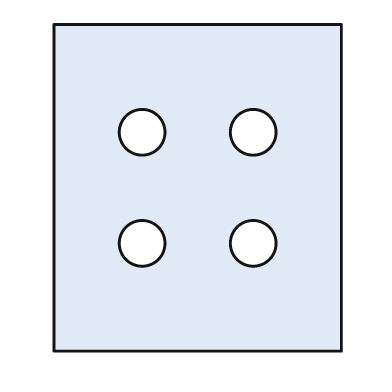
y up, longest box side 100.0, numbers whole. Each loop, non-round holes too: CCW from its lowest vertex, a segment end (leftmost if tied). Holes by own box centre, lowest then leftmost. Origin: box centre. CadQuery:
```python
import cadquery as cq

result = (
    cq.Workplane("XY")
    .moveTo(-44.0, -50.0)
    .lineTo(44.0, -50.0)
    .lineTo(44.0, 50.0)
    .lineTo(-44.0, 50.0)
    .close()
    .moveTo(-17.0, -17.0)
    .circle(7.0)
    .moveTo(17.0, -17.0)
    .circle(7.0)
    .moveTo(-17.0, 17.0)
    .circle(7.0)
    .moveTo(17.0, 17.0)
    .circle(7.0)
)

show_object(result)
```